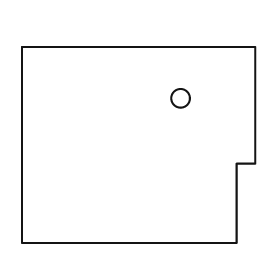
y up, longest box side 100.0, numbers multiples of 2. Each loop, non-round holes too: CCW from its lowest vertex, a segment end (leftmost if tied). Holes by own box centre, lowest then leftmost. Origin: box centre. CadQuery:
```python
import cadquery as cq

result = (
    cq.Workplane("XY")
    .moveTo(-50.0, -42.0)
    .lineTo(42.0, -42.0)
    .lineTo(42.0, -8.0)
    .lineTo(50.0, -8.0)
    .lineTo(50.0, 42.0)
    .lineTo(-50.0, 42.0)
    .close()
    .moveTo(18.0, 20.0)
    .circle(4.0)
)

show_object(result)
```